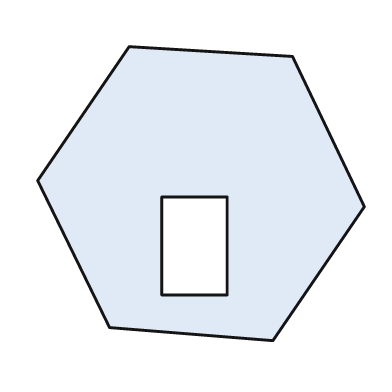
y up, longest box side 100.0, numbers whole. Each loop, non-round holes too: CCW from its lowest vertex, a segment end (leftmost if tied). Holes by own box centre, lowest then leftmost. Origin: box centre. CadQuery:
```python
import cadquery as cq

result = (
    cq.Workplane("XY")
    .moveTo(22.0, -45.0)
    .lineTo(50.0, -4.0)
    .lineTo(28.0, 42.0)
    .lineTo(-22.0, 45.0)
    .lineTo(-50.0, 4.0)
    .lineTo(-28.0, -41.0)
    .close()
    .moveTo(-12.0, -31.0)
    .lineTo(8.0, -31.0)
    .lineTo(8.0, -1.0)
    .lineTo(-12.0, -1.0)
    .close()
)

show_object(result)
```